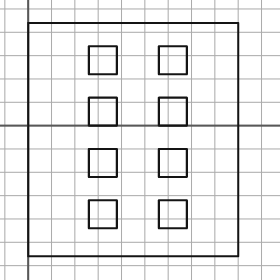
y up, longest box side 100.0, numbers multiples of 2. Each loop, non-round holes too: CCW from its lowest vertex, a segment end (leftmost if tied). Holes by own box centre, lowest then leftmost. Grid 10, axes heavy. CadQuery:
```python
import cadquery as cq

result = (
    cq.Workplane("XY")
    .moveTo(0.0, -56.0)
    .lineTo(90.0, -56.0)
    .lineTo(90.0, 44.0)
    .lineTo(0.0, 44.0)
    .close()
    .moveTo(26.0, -44.0)
    .lineTo(38.0, -44.0)
    .lineTo(38.0, -32.0)
    .lineTo(26.0, -32.0)
    .close()
    .moveTo(56.0, -44.0)
    .lineTo(68.0, -44.0)
    .lineTo(68.0, -32.0)
    .lineTo(56.0, -32.0)
    .close()
    .moveTo(26.0, -22.0)
    .lineTo(38.0, -22.0)
    .lineTo(38.0, -10.0)
    .lineTo(26.0, -10.0)
    .close()
    .moveTo(56.0, -22.0)
    .lineTo(68.0, -22.0)
    .lineTo(68.0, -10.0)
    .lineTo(56.0, -10.0)
    .close()
    .moveTo(26.0, 0.0)
    .lineTo(38.0, 0.0)
    .lineTo(38.0, 12.0)
    .lineTo(26.0, 12.0)
    .close()
    .moveTo(56.0, 0.0)
    .lineTo(68.0, 0.0)
    .lineTo(68.0, 12.0)
    .lineTo(56.0, 12.0)
    .close()
    .moveTo(26.0, 22.0)
    .lineTo(38.0, 22.0)
    .lineTo(38.0, 34.0)
    .lineTo(26.0, 34.0)
    .close()
    .moveTo(56.0, 22.0)
    .lineTo(68.0, 22.0)
    .lineTo(68.0, 34.0)
    .lineTo(56.0, 34.0)
    .close()
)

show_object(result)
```